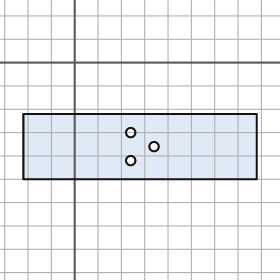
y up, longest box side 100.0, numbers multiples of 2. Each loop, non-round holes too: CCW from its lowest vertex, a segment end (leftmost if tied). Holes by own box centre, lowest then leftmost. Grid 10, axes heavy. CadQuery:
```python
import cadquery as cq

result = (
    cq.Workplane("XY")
    .moveTo(-22.0, -50.0)
    .lineTo(78.0, -50.0)
    .lineTo(78.0, -22.0)
    .lineTo(-22.0, -22.0)
    .close()
    .moveTo(24.0, -42.0)
    .circle(2.0)
    .moveTo(34.0, -36.0)
    .circle(2.0)
    .moveTo(24.0, -30.0)
    .circle(2.0)
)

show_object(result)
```